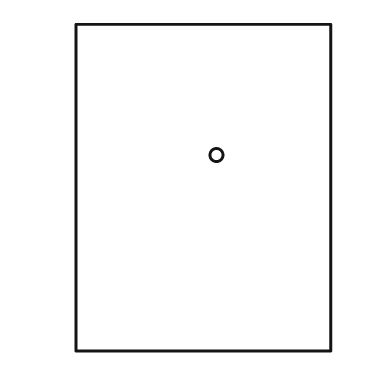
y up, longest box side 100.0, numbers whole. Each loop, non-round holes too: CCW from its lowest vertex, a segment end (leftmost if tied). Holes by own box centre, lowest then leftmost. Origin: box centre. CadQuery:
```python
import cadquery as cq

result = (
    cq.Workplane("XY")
    .moveTo(-39.0, -50.0)
    .lineTo(39.0, -50.0)
    .lineTo(39.0, 50.0)
    .lineTo(-39.0, 50.0)
    .close()
    .moveTo(4.0, 10.0)
    .circle(2.0)
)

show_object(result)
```